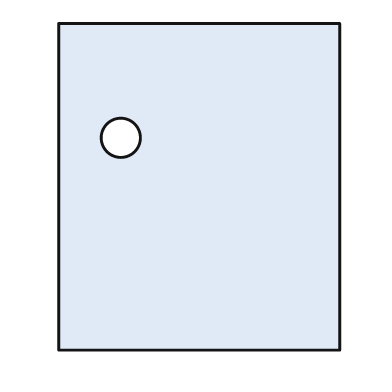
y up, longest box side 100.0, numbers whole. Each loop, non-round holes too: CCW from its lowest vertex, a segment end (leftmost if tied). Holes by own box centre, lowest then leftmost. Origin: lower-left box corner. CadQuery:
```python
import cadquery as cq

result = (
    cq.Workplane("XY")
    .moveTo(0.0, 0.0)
    .lineTo(86.0, 0.0)
    .lineTo(86.0, 100.0)
    .lineTo(0.0, 100.0)
    .close()
    .moveTo(19.0, 65.0)
    .circle(6.0)
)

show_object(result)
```